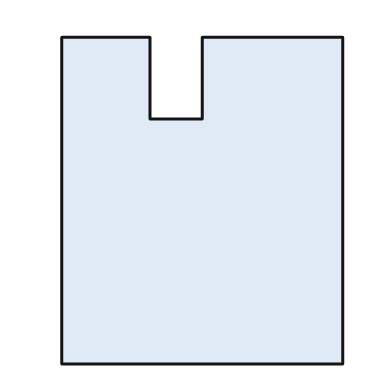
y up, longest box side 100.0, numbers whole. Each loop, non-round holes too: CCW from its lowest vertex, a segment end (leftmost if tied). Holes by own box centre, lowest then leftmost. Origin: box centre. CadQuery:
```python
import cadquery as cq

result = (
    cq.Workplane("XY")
    .moveTo(-43.0, -50.0)
    .lineTo(43.0, -50.0)
    .lineTo(43.0, 50.0)
    .lineTo(0.0, 50.0)
    .lineTo(0.0, 25.0)
    .lineTo(-16.0, 25.0)
    .lineTo(-16.0, 50.0)
    .lineTo(-43.0, 50.0)
    .close()
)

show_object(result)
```